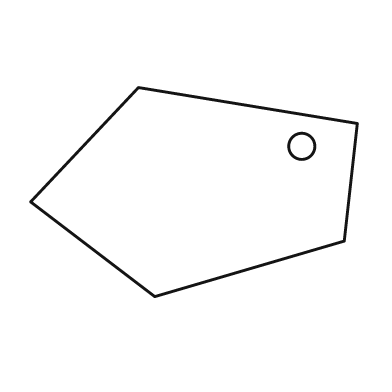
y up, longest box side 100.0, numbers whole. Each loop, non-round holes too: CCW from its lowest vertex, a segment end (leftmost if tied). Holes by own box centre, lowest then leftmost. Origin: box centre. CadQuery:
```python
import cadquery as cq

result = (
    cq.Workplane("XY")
    .moveTo(-12.0, -32.0)
    .lineTo(46.0, -15.0)
    .lineTo(50.0, 21.0)
    .lineTo(-17.0, 32.0)
    .lineTo(-50.0, -3.0)
    .close()
    .moveTo(33.0, 14.0)
    .circle(4.0)
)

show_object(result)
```